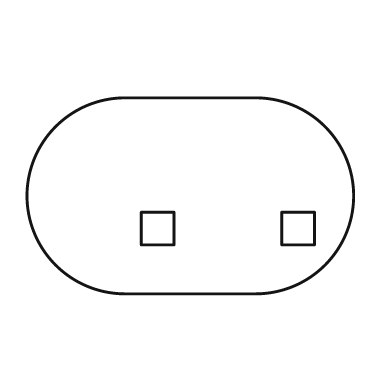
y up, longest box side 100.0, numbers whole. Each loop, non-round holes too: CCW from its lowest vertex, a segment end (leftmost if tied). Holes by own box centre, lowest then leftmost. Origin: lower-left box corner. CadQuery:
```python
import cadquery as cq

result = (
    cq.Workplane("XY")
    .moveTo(30.0, 0.0)
    .lineTo(70.0, 0.0)
    .threePointArc((100.0, 30.0), (70.0, 60.0))
    .lineTo(30.0, 60.0)
    .threePointArc((0.0, 30.0), (30.0, 0.0))
    .close()
    .moveTo(35.0, 15.0)
    .lineTo(45.0, 15.0)
    .lineTo(45.0, 25.0)
    .lineTo(35.0, 25.0)
    .close()
    .moveTo(78.0, 15.0)
    .lineTo(88.0, 15.0)
    .lineTo(88.0, 25.0)
    .lineTo(78.0, 25.0)
    .close()
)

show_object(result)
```